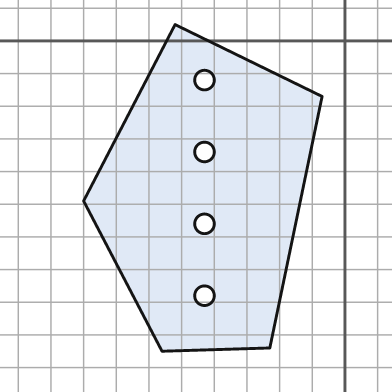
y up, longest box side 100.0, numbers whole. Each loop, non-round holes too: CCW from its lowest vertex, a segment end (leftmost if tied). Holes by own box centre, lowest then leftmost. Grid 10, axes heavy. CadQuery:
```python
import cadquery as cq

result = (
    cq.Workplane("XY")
    .moveTo(-56.0, -95.0)
    .lineTo(-23.0, -94.0)
    .lineTo(-7.0, -17.0)
    .lineTo(-52.0, 5.0)
    .lineTo(-80.0, -49.0)
    .close()
    .moveTo(-43.0, -78.0)
    .circle(3.0)
    .moveTo(-43.0, -56.0)
    .circle(3.0)
    .moveTo(-43.0, -34.0)
    .circle(3.0)
    .moveTo(-43.0, -12.0)
    .circle(3.0)
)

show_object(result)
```